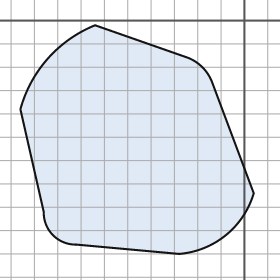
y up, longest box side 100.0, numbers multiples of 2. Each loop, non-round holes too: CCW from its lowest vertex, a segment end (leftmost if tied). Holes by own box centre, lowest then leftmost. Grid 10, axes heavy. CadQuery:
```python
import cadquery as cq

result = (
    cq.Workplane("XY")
    .moveTo(-28.0, -100.0)
    .threePointArc((-8.0, -92.0), (4.0, -74.0))
    .lineTo(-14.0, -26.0)
    .threePointArc((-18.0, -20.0), (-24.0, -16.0))
    .lineTo(-64.0, -2.0)
    .threePointArc((-84.0, -16.0), (-96.0, -38.0))
    .lineTo(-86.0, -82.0)
    .threePointArc((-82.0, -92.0), (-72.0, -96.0))
    .close()
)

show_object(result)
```